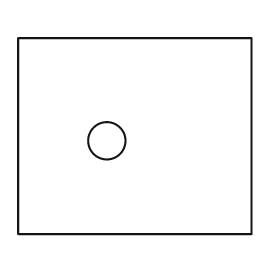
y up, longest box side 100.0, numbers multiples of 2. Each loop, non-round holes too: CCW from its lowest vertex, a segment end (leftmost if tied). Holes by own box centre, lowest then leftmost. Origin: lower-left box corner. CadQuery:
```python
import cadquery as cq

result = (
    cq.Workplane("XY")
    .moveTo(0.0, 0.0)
    .lineTo(100.0, 0.0)
    .lineTo(100.0, 84.0)
    .lineTo(0.0, 84.0)
    .close()
    .moveTo(38.0, 40.0)
    .circle(8.0)
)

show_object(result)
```